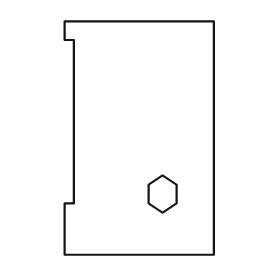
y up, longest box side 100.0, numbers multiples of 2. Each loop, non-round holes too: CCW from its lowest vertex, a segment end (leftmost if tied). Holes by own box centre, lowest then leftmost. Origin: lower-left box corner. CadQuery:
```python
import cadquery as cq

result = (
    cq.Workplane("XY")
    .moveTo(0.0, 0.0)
    .lineTo(64.0, 0.0)
    .lineTo(64.0, 100.0)
    .lineTo(0.0, 100.0)
    .lineTo(0.0, 92.0)
    .lineTo(4.0, 92.0)
    .lineTo(4.0, 22.0)
    .lineTo(0.0, 22.0)
    .close()
    .moveTo(42.0, 18.0)
    .lineTo(48.0, 22.0)
    .lineTo(48.0, 30.0)
    .lineTo(42.0, 34.0)
    .lineTo(36.0, 30.0)
    .lineTo(36.0, 22.0)
    .close()
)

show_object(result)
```